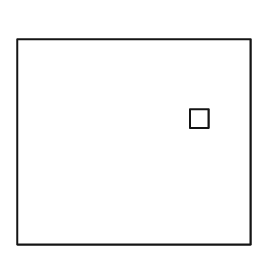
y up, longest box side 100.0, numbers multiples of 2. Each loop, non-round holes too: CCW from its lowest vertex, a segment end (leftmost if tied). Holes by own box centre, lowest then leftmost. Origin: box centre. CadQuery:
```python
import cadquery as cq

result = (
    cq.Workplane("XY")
    .moveTo(-50.0, -44.0)
    .lineTo(50.0, -44.0)
    .lineTo(50.0, 44.0)
    .lineTo(-50.0, 44.0)
    .close()
    .moveTo(24.0, 6.0)
    .lineTo(32.0, 6.0)
    .lineTo(32.0, 14.0)
    .lineTo(24.0, 14.0)
    .close()
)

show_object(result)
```